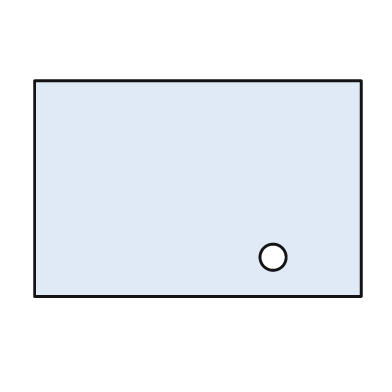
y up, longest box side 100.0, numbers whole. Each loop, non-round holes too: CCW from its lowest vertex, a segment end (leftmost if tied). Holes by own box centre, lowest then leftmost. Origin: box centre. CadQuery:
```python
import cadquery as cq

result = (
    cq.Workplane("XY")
    .moveTo(-50.0, -33.0)
    .lineTo(50.0, -33.0)
    .lineTo(50.0, 33.0)
    .lineTo(-50.0, 33.0)
    .close()
    .moveTo(23.0, -21.0)
    .circle(4.0)
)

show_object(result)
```